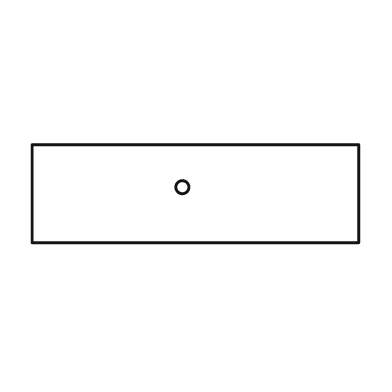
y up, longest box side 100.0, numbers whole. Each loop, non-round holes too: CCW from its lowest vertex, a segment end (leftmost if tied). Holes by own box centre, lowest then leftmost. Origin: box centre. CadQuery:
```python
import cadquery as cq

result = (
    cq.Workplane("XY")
    .moveTo(-50.0, -15.0)
    .lineTo(50.0, -15.0)
    .lineTo(50.0, 15.0)
    .lineTo(-50.0, 15.0)
    .close()
    .moveTo(-4.0, 2.0)
    .circle(2.0)
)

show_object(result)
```